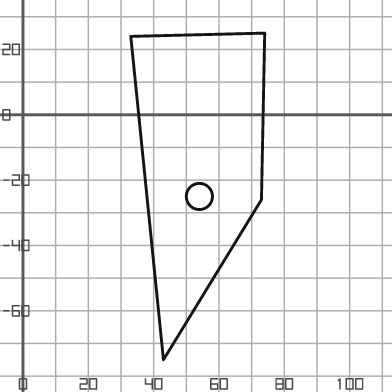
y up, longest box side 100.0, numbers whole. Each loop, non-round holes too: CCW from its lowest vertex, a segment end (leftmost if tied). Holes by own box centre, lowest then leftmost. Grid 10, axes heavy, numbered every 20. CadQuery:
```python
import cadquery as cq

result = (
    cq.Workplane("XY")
    .moveTo(43.0, -75.0)
    .lineTo(73.0, -26.0)
    .lineTo(74.0, 25.0)
    .lineTo(33.0, 24.0)
    .close()
    .moveTo(54.0, -25.0)
    .circle(4.0)
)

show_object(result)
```